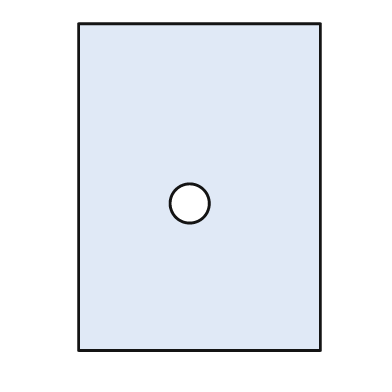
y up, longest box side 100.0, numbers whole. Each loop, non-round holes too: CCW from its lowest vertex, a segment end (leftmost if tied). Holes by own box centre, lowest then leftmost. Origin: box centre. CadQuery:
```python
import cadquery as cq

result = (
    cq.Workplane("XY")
    .moveTo(-37.0, -50.0)
    .lineTo(37.0, -50.0)
    .lineTo(37.0, 50.0)
    .lineTo(-37.0, 50.0)
    .close()
    .moveTo(-3.0, -5.0)
    .circle(6.0)
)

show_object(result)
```